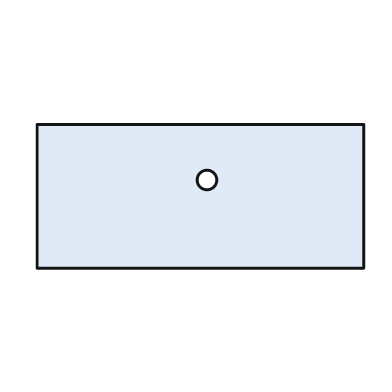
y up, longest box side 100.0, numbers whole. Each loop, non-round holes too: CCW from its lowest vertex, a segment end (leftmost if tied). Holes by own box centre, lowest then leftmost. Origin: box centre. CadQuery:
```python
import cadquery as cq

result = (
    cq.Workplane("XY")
    .moveTo(-50.0, -22.0)
    .lineTo(50.0, -22.0)
    .lineTo(50.0, 22.0)
    .lineTo(-50.0, 22.0)
    .close()
    .moveTo(2.0, 5.0)
    .circle(3.0)
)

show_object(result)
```